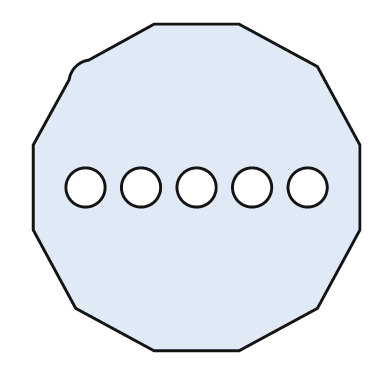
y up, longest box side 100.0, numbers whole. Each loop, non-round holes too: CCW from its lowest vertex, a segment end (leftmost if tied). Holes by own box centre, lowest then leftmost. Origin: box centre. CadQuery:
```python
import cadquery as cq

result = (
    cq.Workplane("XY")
    .moveTo(-13.0, -50.0)
    .lineTo(13.0, -50.0)
    .lineTo(37.0, -37.0)
    .lineTo(50.0, -13.0)
    .lineTo(50.0, 13.0)
    .lineTo(37.0, 37.0)
    .lineTo(13.0, 50.0)
    .lineTo(-13.0, 50.0)
    .lineTo(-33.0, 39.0)
    .threePointArc((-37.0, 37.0), (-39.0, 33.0))
    .lineTo(-50.0, 13.0)
    .lineTo(-50.0, -13.0)
    .lineTo(-37.0, -37.0)
    .close()
    .moveTo(-34.0, 0.0)
    .circle(6.0)
    .moveTo(-17.0, 0.0)
    .circle(6.0)
    .moveTo(0.0, 0.0)
    .circle(6.0)
    .moveTo(17.0, 0.0)
    .circle(6.0)
    .moveTo(34.0, 0.0)
    .circle(6.0)
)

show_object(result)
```